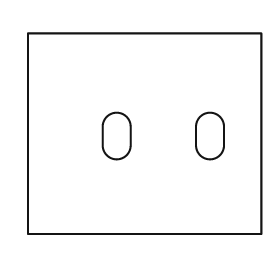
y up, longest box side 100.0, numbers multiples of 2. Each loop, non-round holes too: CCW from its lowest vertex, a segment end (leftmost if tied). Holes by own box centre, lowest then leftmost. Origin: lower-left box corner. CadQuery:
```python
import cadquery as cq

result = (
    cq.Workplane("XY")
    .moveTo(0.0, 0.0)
    .lineTo(100.0, 0.0)
    .lineTo(100.0, 86.0)
    .lineTo(0.0, 86.0)
    .close()
    .moveTo(32.0, 38.0)
    .threePointArc((38.0, 32.0), (44.0, 38.0))
    .lineTo(44.0, 46.0)
    .threePointArc((38.0, 52.0), (32.0, 46.0))
    .close()
    .moveTo(72.0, 38.0)
    .threePointArc((78.0, 32.0), (84.0, 38.0))
    .lineTo(84.0, 46.0)
    .threePointArc((78.0, 52.0), (72.0, 46.0))
    .close()
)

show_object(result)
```